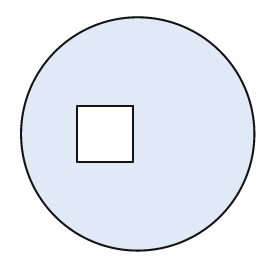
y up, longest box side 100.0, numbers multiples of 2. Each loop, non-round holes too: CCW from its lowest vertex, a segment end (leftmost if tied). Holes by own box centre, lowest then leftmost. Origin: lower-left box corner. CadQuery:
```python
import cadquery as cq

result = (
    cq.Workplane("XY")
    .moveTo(50.0, 50.0)
    .circle(50.0)
    .moveTo(24.0, 38.0)
    .lineTo(48.0, 38.0)
    .lineTo(48.0, 62.0)
    .lineTo(24.0, 62.0)
    .close()
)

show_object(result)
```